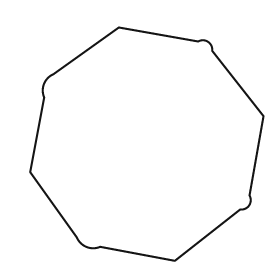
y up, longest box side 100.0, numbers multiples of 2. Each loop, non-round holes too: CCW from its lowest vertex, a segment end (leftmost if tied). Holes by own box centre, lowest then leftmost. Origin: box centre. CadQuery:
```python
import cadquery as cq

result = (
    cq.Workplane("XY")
    .moveTo(12.0, -50.0)
    .lineTo(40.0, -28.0)
    .threePointArc((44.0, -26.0), (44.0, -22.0))
    .lineTo(50.0, 12.0)
    .lineTo(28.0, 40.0)
    .threePointArc((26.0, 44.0), (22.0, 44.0))
    .lineTo(-12.0, 50.0)
    .lineTo(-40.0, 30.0)
    .threePointArc((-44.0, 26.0), (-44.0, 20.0))
    .lineTo(-50.0, -12.0)
    .lineTo(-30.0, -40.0)
    .threePointArc((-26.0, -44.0), (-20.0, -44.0))
    .close()
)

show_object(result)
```